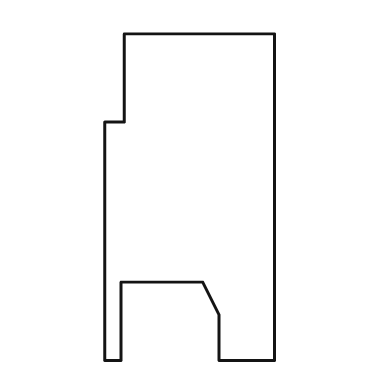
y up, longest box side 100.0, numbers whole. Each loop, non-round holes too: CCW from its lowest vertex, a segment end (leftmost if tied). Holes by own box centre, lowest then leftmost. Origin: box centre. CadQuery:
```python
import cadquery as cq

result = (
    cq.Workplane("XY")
    .moveTo(-26.0, -50.0)
    .lineTo(-21.0, -50.0)
    .lineTo(-21.0, -26.0)
    .lineTo(4.0, -26.0)
    .lineTo(9.0, -36.0)
    .lineTo(9.0, -50.0)
    .lineTo(26.0, -50.0)
    .lineTo(26.0, 50.0)
    .lineTo(-20.0, 50.0)
    .lineTo(-20.0, 23.0)
    .lineTo(-26.0, 23.0)
    .close()
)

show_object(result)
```